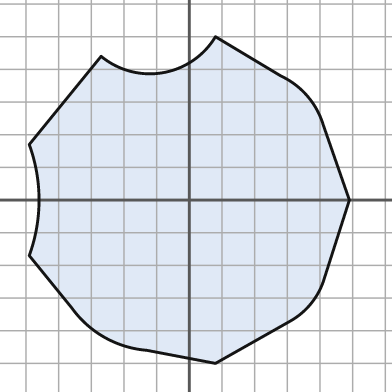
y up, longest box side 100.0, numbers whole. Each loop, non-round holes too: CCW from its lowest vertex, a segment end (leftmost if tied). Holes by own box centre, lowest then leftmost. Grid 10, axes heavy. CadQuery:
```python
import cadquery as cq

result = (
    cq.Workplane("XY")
    .moveTo(8.0, -50.0)
    .lineTo(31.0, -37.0)
    .threePointArc((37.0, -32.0), (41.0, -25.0))
    .lineTo(49.0, 0.0)
    .lineTo(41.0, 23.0)
    .threePointArc((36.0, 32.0), (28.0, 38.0))
    .lineTo(8.0, 50.0)
    .threePointArc((-8.0, 39.0), (-27.0, 44.0))
    .lineTo(-49.0, 17.0)
    .threePointArc((-46.0, 0.0), (-49.0, -17.0))
    .lineTo(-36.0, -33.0)
    .threePointArc((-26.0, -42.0), (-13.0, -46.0))
    .close()
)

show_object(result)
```